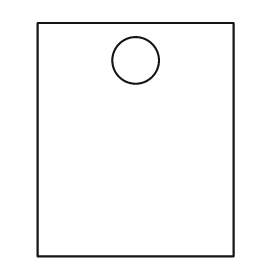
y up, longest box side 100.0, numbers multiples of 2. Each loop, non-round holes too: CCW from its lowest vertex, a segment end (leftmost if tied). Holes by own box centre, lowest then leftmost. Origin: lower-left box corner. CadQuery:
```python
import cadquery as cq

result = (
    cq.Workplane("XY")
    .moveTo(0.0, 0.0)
    .lineTo(84.0, 0.0)
    .lineTo(84.0, 100.0)
    .lineTo(0.0, 100.0)
    .close()
    .moveTo(42.0, 84.0)
    .circle(10.0)
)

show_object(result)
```